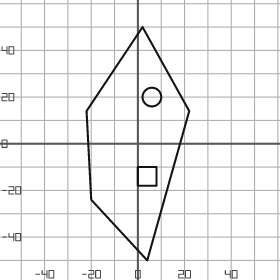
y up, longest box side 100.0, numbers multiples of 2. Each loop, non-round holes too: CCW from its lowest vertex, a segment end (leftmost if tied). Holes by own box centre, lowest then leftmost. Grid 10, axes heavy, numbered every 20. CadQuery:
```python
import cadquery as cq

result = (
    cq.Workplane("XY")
    .moveTo(4.0, -50.0)
    .lineTo(22.0, 14.0)
    .lineTo(2.0, 50.0)
    .lineTo(-22.0, 14.0)
    .lineTo(-20.0, -24.0)
    .close()
    .moveTo(0.0, -18.0)
    .lineTo(8.0, -18.0)
    .lineTo(8.0, -10.0)
    .lineTo(0.0, -10.0)
    .close()
    .moveTo(6.0, 20.0)
    .circle(4.0)
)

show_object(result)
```